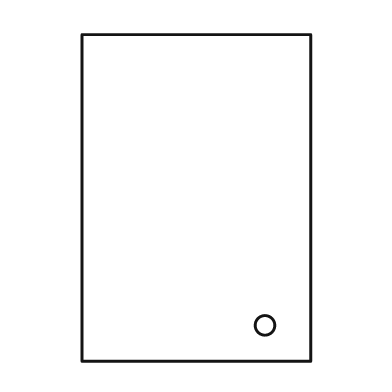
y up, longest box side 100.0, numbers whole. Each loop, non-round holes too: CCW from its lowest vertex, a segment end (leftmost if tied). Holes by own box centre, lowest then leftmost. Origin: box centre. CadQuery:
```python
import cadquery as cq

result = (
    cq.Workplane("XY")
    .moveTo(-35.0, -50.0)
    .lineTo(35.0, -50.0)
    .lineTo(35.0, 50.0)
    .lineTo(-35.0, 50.0)
    .close()
    .moveTo(21.0, -39.0)
    .circle(3.0)
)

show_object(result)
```